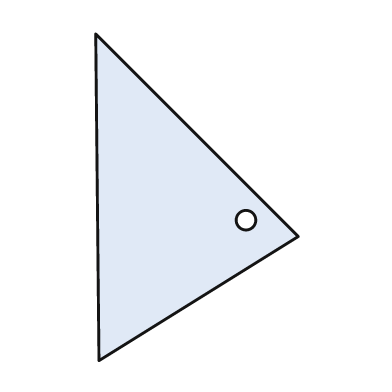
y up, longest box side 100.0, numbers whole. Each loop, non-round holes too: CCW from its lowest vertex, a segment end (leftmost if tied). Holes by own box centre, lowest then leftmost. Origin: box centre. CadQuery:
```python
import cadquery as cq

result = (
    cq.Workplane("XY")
    .moveTo(-30.0, -50.0)
    .lineTo(31.0, -12.0)
    .lineTo(-31.0, 50.0)
    .close()
    .moveTo(15.0, -7.0)
    .circle(3.0)
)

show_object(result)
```